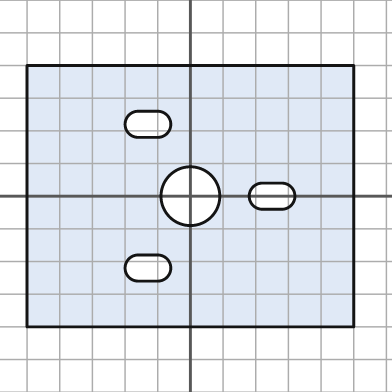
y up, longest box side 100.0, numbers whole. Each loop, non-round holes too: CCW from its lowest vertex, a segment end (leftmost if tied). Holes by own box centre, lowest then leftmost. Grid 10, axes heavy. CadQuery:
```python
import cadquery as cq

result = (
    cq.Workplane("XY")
    .moveTo(-50.0, -40.0)
    .lineTo(50.0, -40.0)
    .lineTo(50.0, 40.0)
    .lineTo(-50.0, 40.0)
    .close()
    .moveTo(-16.0, -26.0)
    .lineTo(-10.0, -26.0)
    .threePointArc((-6.0, -22.0), (-10.0, -18.0))
    .lineTo(-16.0, -18.0)
    .threePointArc((-20.0, -22.0), (-16.0, -26.0))
    .close()
    .moveTo(0.0, 0.0)
    .circle(9.0)
    .moveTo(22.0, -4.0)
    .lineTo(28.0, -4.0)
    .threePointArc((32.0, 0.0), (28.0, 4.0))
    .lineTo(22.0, 4.0)
    .threePointArc((18.0, 0.0), (22.0, -4.0))
    .close()
    .moveTo(-16.0, 18.0)
    .lineTo(-10.0, 18.0)
    .threePointArc((-6.0, 22.0), (-10.0, 26.0))
    .lineTo(-16.0, 26.0)
    .threePointArc((-20.0, 22.0), (-16.0, 18.0))
    .close()
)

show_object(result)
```